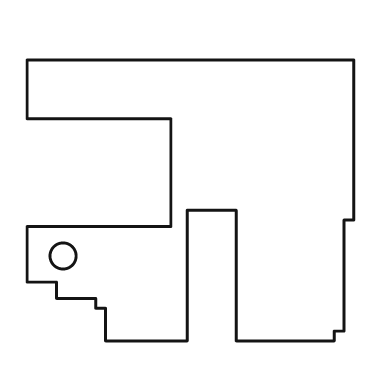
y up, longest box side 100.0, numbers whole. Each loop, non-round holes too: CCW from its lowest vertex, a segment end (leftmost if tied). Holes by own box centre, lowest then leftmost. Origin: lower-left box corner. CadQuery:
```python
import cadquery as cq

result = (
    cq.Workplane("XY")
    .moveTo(24.0, 0.0)
    .lineTo(49.0, 0.0)
    .lineTo(49.0, 40.0)
    .lineTo(64.0, 40.0)
    .lineTo(64.0, 0.0)
    .lineTo(94.0, 0.0)
    .lineTo(94.0, 3.0)
    .lineTo(97.0, 3.0)
    .lineTo(97.0, 37.0)
    .lineTo(100.0, 37.0)
    .lineTo(100.0, 86.0)
    .lineTo(0.0, 86.0)
    .lineTo(0.0, 68.0)
    .lineTo(44.0, 68.0)
    .lineTo(44.0, 35.0)
    .lineTo(0.0, 35.0)
    .lineTo(0.0, 18.0)
    .lineTo(9.0, 18.0)
    .lineTo(9.0, 13.0)
    .lineTo(21.0, 13.0)
    .lineTo(21.0, 10.0)
    .lineTo(24.0, 10.0)
    .close()
    .moveTo(11.0, 26.0)
    .circle(4.0)
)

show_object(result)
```